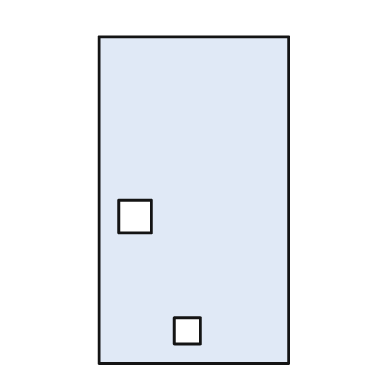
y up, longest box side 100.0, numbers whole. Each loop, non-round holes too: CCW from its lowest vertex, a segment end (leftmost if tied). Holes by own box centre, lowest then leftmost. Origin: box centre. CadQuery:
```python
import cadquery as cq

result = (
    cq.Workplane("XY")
    .moveTo(-29.0, -50.0)
    .lineTo(29.0, -50.0)
    .lineTo(29.0, 50.0)
    .lineTo(-29.0, 50.0)
    .close()
    .moveTo(-6.0, -44.0)
    .lineTo(2.0, -44.0)
    .lineTo(2.0, -36.0)
    .lineTo(-6.0, -36.0)
    .close()
    .moveTo(-23.0, -10.0)
    .lineTo(-13.0, -10.0)
    .lineTo(-13.0, 0.0)
    .lineTo(-23.0, 0.0)
    .close()
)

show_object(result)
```